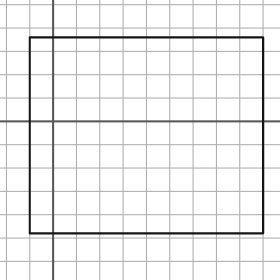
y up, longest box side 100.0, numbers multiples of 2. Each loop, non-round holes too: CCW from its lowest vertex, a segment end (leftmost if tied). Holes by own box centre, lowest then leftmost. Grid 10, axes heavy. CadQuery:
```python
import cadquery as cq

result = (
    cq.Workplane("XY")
    .moveTo(-10.0, -48.0)
    .lineTo(90.0, -48.0)
    .lineTo(90.0, 36.0)
    .lineTo(-10.0, 36.0)
    .close()
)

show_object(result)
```